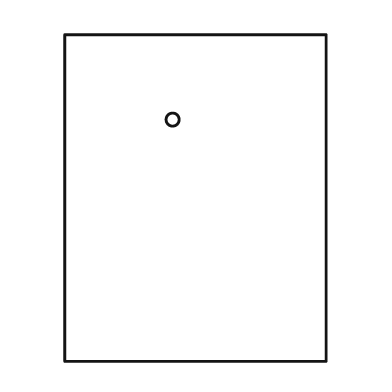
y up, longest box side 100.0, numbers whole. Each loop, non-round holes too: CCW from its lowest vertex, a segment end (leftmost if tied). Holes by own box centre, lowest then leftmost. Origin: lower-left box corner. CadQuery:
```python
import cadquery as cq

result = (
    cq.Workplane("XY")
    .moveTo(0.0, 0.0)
    .lineTo(80.0, 0.0)
    .lineTo(80.0, 100.0)
    .lineTo(0.0, 100.0)
    .close()
    .moveTo(33.0, 74.0)
    .circle(2.0)
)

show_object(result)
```